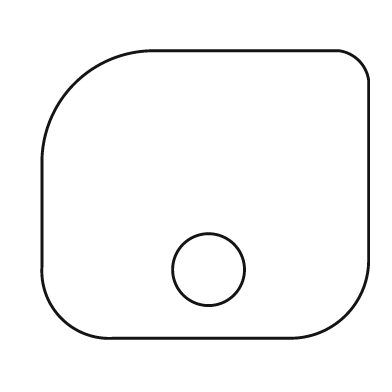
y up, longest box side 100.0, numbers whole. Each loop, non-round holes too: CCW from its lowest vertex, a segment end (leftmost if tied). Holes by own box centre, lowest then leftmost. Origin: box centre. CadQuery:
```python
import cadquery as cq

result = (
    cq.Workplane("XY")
    .moveTo(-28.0, -44.0)
    .lineTo(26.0, -44.0)
    .threePointArc((43.0, -37.0), (50.0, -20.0))
    .lineTo(50.0, 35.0)
    .threePointArc((47.0, 41.0), (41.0, 44.0))
    .lineTo(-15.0, 44.0)
    .threePointArc((-40.0, 34.0), (-50.0, 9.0))
    .lineTo(-50.0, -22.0)
    .threePointArc((-44.0, -38.0), (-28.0, -44.0))
    .close()
    .moveTo(1.0, -23.0)
    .circle(11.0)
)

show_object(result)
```